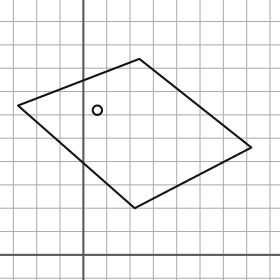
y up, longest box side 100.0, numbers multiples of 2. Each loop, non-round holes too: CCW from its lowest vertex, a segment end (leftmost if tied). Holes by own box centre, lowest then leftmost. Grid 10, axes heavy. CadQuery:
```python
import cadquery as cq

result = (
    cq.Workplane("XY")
    .moveTo(22.0, 20.0)
    .lineTo(72.0, 46.0)
    .lineTo(24.0, 84.0)
    .lineTo(-28.0, 64.0)
    .close()
    .moveTo(6.0, 62.0)
    .circle(2.0)
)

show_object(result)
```